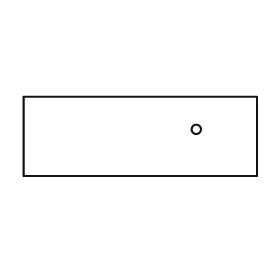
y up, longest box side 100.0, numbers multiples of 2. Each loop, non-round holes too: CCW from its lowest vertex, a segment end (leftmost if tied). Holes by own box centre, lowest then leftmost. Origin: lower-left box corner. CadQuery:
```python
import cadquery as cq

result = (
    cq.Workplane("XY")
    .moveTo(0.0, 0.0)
    .lineTo(100.0, 0.0)
    .lineTo(100.0, 34.0)
    .lineTo(0.0, 34.0)
    .close()
    .moveTo(74.0, 20.0)
    .circle(2.0)
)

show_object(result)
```